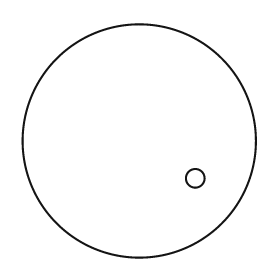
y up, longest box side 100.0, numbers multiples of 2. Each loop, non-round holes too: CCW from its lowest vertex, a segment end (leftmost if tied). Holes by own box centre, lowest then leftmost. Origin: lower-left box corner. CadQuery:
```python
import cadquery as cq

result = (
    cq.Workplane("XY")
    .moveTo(50.0, 50.0)
    .circle(50.0)
    .moveTo(74.0, 34.0)
    .circle(4.0)
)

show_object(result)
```